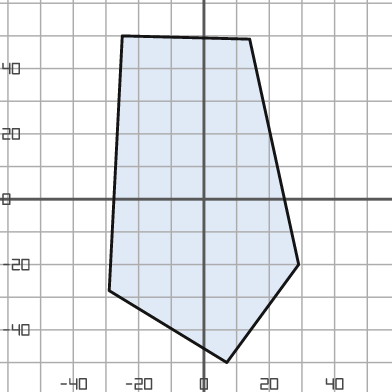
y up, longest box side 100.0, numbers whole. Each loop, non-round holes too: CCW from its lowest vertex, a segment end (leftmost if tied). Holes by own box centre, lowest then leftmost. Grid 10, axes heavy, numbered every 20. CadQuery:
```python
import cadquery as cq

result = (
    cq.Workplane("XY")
    .moveTo(7.0, -50.0)
    .lineTo(29.0, -20.0)
    .lineTo(14.0, 49.0)
    .lineTo(-25.0, 50.0)
    .lineTo(-29.0, -28.0)
    .close()
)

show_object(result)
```